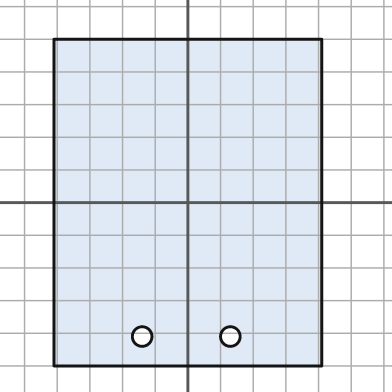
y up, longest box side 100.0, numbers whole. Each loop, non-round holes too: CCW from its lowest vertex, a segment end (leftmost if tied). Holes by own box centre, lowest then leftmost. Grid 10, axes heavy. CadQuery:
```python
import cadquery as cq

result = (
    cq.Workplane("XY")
    .moveTo(-41.0, -50.0)
    .lineTo(41.0, -50.0)
    .lineTo(41.0, 50.0)
    .lineTo(-41.0, 50.0)
    .close()
    .moveTo(-14.0, -41.0)
    .circle(3.0)
    .moveTo(13.0, -41.0)
    .circle(3.0)
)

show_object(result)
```